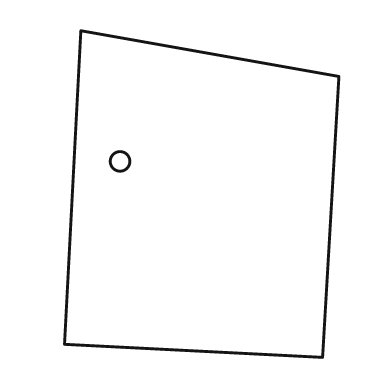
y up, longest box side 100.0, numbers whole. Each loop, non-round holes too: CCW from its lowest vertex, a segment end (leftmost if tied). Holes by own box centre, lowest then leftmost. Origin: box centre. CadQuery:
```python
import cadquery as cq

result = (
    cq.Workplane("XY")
    .moveTo(37.0, -50.0)
    .lineTo(42.0, 36.0)
    .lineTo(-37.0, 50.0)
    .lineTo(-42.0, -46.0)
    .close()
    .moveTo(-25.0, 10.0)
    .circle(3.0)
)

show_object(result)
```